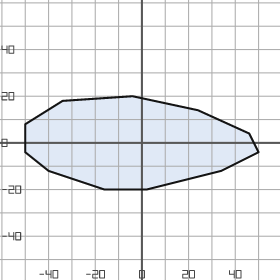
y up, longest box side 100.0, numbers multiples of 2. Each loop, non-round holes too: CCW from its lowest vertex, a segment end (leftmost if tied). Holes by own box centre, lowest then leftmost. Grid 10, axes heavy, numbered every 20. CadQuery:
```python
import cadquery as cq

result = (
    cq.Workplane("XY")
    .moveTo(-16.0, -20.0)
    .lineTo(2.0, -20.0)
    .lineTo(34.0, -12.0)
    .lineTo(50.0, -4.0)
    .lineTo(46.0, 4.0)
    .lineTo(24.0, 14.0)
    .lineTo(-4.0, 20.0)
    .lineTo(-34.0, 18.0)
    .lineTo(-50.0, 8.0)
    .lineTo(-50.0, -4.0)
    .lineTo(-40.0, -12.0)
    .close()
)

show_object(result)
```